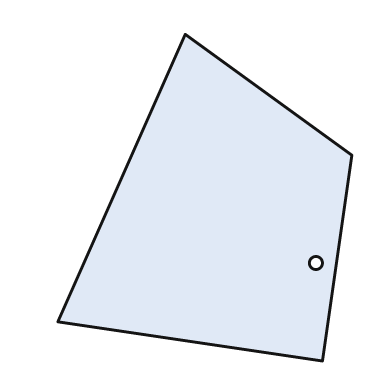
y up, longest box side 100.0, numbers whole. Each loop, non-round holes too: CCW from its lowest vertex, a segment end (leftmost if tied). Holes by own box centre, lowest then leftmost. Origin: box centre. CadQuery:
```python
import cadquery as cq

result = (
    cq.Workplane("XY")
    .moveTo(36.0, -50.0)
    .lineTo(45.0, 13.0)
    .lineTo(-6.0, 50.0)
    .lineTo(-45.0, -38.0)
    .close()
    .moveTo(34.0, -20.0)
    .circle(2.0)
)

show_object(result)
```